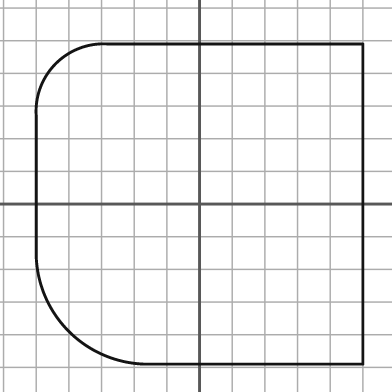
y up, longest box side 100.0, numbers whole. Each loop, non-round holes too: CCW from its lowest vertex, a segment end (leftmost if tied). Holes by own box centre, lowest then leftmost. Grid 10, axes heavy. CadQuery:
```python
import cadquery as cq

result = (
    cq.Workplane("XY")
    .moveTo(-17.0, -49.0)
    .lineTo(50.0, -49.0)
    .lineTo(50.0, 49.0)
    .lineTo(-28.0, 49.0)
    .threePointArc((-44.0, 43.0), (-50.0, 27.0))
    .lineTo(-50.0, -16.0)
    .threePointArc((-40.0, -39.0), (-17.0, -49.0))
    .close()
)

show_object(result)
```